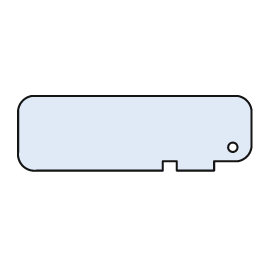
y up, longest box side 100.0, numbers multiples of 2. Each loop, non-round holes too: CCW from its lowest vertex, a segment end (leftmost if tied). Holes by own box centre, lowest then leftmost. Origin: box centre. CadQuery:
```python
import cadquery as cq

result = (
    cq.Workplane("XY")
    .moveTo(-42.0, -16.0)
    .lineTo(12.0, -16.0)
    .lineTo(12.0, -12.0)
    .lineTo(18.0, -12.0)
    .lineTo(18.0, -16.0)
    .lineTo(34.0, -16.0)
    .lineTo(34.0, -12.0)
    .lineTo(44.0, -12.0)
    .threePointArc((48.0, -10.0), (50.0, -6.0))
    .lineTo(50.0, 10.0)
    .threePointArc((48.0, 14.0), (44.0, 16.0))
    .lineTo(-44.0, 16.0)
    .threePointArc((-48.0, 14.0), (-50.0, 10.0))
    .lineTo(-50.0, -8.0)
    .threePointArc((-48.0, -14.0), (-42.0, -16.0))
    .close()
    .moveTo(42.0, -6.0)
    .circle(2.0)
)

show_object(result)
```